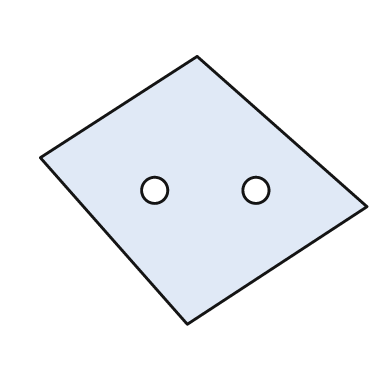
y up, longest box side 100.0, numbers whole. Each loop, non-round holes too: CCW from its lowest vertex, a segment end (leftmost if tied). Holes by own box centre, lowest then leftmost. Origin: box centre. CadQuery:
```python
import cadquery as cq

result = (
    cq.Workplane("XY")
    .moveTo(-5.0, -41.0)
    .lineTo(50.0, -5.0)
    .lineTo(-2.0, 41.0)
    .lineTo(-50.0, 10.0)
    .close()
    .moveTo(-15.0, 0.0)
    .circle(4.0)
    .moveTo(16.0, 0.0)
    .circle(4.0)
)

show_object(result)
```